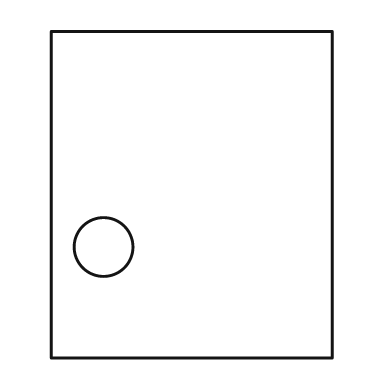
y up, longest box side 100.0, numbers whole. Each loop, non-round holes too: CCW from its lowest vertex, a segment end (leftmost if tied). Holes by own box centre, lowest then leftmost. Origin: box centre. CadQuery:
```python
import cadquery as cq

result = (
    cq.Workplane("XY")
    .moveTo(-43.0, -50.0)
    .lineTo(43.0, -50.0)
    .lineTo(43.0, 50.0)
    .lineTo(-43.0, 50.0)
    .close()
    .moveTo(-27.0, -16.0)
    .circle(9.0)
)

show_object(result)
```